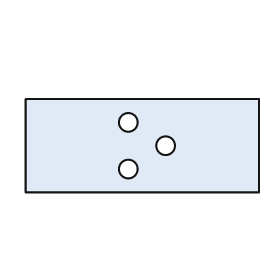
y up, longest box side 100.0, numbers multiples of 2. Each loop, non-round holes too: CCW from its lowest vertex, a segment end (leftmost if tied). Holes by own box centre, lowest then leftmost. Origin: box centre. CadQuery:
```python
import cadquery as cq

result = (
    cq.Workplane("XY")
    .moveTo(-50.0, -20.0)
    .lineTo(50.0, -20.0)
    .lineTo(50.0, 20.0)
    .lineTo(-50.0, 20.0)
    .close()
    .moveTo(-6.0, -10.0)
    .circle(4.0)
    .moveTo(10.0, 0.0)
    .circle(4.0)
    .moveTo(-6.0, 10.0)
    .circle(4.0)
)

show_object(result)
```